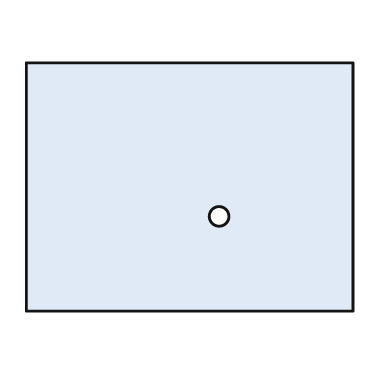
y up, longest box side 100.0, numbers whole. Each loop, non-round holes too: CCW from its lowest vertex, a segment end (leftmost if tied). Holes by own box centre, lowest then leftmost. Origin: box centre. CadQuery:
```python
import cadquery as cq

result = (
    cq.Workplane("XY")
    .moveTo(-50.0, -38.0)
    .lineTo(50.0, -38.0)
    .lineTo(50.0, 38.0)
    .lineTo(-50.0, 38.0)
    .close()
    .moveTo(9.0, -9.0)
    .circle(3.0)
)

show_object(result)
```